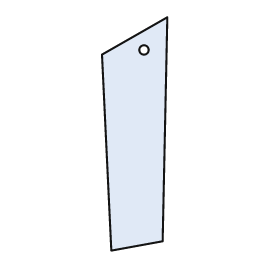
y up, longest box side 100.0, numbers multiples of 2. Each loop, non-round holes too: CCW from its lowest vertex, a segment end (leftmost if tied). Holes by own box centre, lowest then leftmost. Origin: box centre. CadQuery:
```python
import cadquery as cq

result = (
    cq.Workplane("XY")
    .moveTo(-10.0, -50.0)
    .lineTo(12.0, -46.0)
    .lineTo(14.0, 50.0)
    .lineTo(-14.0, 34.0)
    .close()
    .moveTo(4.0, 36.0)
    .circle(2.0)
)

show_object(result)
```